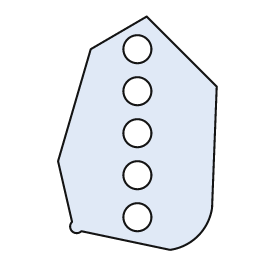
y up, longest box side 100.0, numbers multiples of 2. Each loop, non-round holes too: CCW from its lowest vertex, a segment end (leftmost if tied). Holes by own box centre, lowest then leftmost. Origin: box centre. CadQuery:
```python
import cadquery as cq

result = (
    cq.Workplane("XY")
    .moveTo(14.0, -50.0)
    .threePointArc((26.0, -44.0), (32.0, -32.0))
    .lineTo(34.0, 20.0)
    .lineTo(4.0, 50.0)
    .lineTo(-20.0, 36.0)
    .lineTo(-34.0, -12.0)
    .lineTo(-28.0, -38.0)
    .threePointArc((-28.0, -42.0), (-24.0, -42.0))
    .close()
    .moveTo(0.0, -36.0)
    .circle(6.0)
    .moveTo(0.0, -18.0)
    .circle(6.0)
    .moveTo(0.0, 0.0)
    .circle(6.0)
    .moveTo(0.0, 18.0)
    .circle(6.0)
    .moveTo(0.0, 36.0)
    .circle(6.0)
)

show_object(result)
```